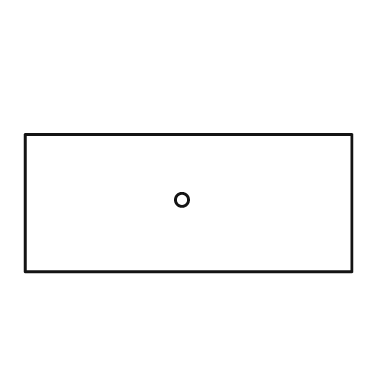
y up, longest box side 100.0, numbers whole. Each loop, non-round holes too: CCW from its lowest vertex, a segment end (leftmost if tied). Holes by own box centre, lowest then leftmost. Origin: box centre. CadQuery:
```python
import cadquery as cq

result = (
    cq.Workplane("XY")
    .moveTo(-50.0, -21.0)
    .lineTo(50.0, -21.0)
    .lineTo(50.0, 21.0)
    .lineTo(-50.0, 21.0)
    .close()
    .moveTo(-2.0, 1.0)
    .circle(2.0)
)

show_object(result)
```